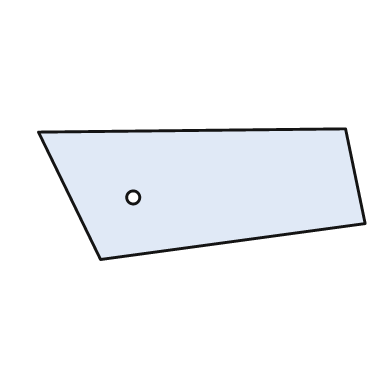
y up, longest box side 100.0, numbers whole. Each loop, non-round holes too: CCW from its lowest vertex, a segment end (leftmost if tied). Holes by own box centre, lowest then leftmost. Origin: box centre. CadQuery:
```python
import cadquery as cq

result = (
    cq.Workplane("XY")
    .moveTo(-31.0, -20.0)
    .lineTo(50.0, -9.0)
    .lineTo(44.0, 20.0)
    .lineTo(-50.0, 19.0)
    .close()
    .moveTo(-21.0, -1.0)
    .circle(2.0)
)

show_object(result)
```